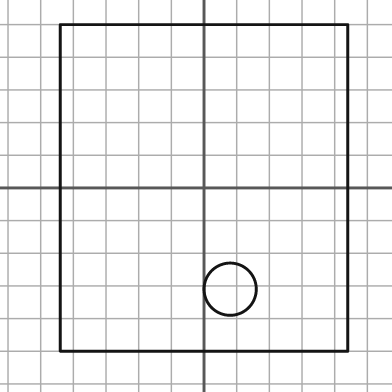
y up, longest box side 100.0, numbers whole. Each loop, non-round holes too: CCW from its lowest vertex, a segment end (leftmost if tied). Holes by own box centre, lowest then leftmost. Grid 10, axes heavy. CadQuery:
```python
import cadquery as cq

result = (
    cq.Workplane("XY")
    .moveTo(-44.0, -50.0)
    .lineTo(44.0, -50.0)
    .lineTo(44.0, 50.0)
    .lineTo(-44.0, 50.0)
    .close()
    .moveTo(8.0, -31.0)
    .circle(8.0)
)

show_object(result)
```